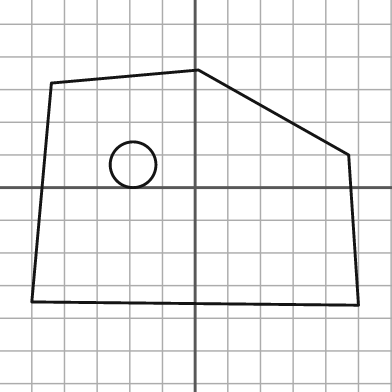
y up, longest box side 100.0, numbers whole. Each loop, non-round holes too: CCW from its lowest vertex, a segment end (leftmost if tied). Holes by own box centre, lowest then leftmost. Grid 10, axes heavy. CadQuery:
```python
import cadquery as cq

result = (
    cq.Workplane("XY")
    .moveTo(50.0, -36.0)
    .lineTo(47.0, 10.0)
    .lineTo(1.0, 36.0)
    .lineTo(-44.0, 32.0)
    .lineTo(-50.0, -35.0)
    .close()
    .moveTo(-19.0, 7.0)
    .circle(7.0)
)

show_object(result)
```